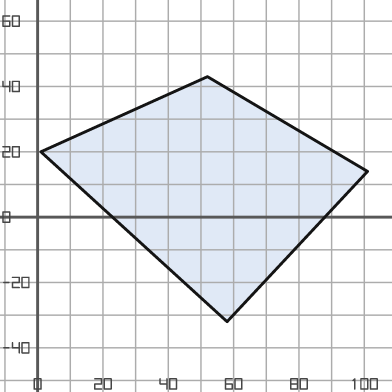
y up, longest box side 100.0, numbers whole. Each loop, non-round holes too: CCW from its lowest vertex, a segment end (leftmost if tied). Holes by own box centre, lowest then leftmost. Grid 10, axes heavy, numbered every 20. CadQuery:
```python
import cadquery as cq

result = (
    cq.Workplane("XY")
    .moveTo(58.0, -32.0)
    .lineTo(101.0, 14.0)
    .lineTo(52.0, 43.0)
    .lineTo(1.0, 20.0)
    .close()
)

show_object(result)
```